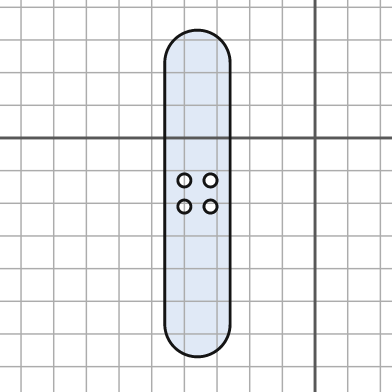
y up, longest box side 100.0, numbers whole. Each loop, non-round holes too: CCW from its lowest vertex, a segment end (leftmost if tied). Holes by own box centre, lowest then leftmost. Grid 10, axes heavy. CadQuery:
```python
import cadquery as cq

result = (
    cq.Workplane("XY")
    .moveTo(-46.0, -57.0)
    .threePointArc((-36.0, -67.0), (-26.0, -57.0))
    .lineTo(-26.0, 23.0)
    .threePointArc((-36.0, 33.0), (-46.0, 23.0))
    .close()
    .moveTo(-40.0, -21.0)
    .circle(2.0)
    .moveTo(-32.0, -21.0)
    .circle(2.0)
    .moveTo(-40.0, -13.0)
    .circle(2.0)
    .moveTo(-32.0, -13.0)
    .circle(2.0)
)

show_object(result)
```